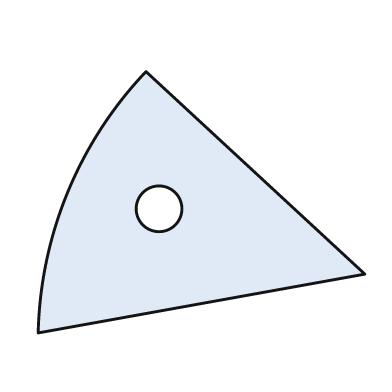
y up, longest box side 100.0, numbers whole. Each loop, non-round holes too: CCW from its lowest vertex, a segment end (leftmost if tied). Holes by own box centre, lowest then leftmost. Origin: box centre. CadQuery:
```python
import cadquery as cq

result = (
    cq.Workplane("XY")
    .moveTo(-50.0, -40.0)
    .lineTo(50.0, -22.0)
    .lineTo(-17.0, 40.0)
    .threePointArc((-41.0, 3.0), (-50.0, -40.0))
    .close()
    .moveTo(-13.0, -2.0)
    .circle(7.0)
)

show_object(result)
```